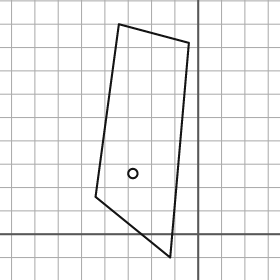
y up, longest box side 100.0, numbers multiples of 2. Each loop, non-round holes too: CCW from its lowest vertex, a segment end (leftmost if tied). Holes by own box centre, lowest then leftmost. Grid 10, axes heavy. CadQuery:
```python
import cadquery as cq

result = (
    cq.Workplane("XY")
    .moveTo(-12.0, -10.0)
    .lineTo(-4.0, 82.0)
    .lineTo(-34.0, 90.0)
    .lineTo(-44.0, 16.0)
    .close()
    .moveTo(-28.0, 26.0)
    .circle(2.0)
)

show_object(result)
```